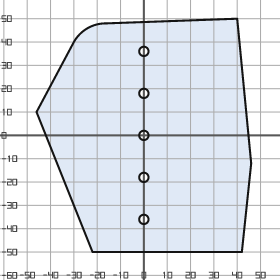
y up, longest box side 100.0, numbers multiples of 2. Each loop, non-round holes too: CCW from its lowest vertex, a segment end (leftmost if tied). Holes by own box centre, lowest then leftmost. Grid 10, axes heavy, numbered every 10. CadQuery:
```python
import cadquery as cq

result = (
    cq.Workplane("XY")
    .moveTo(-22.0, -50.0)
    .lineTo(42.0, -50.0)
    .lineTo(46.0, -12.0)
    .lineTo(40.0, 50.0)
    .lineTo(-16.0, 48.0)
    .threePointArc((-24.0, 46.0), (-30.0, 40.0))
    .lineTo(-46.0, 10.0)
    .close()
    .moveTo(0.0, -36.0)
    .circle(2.0)
    .moveTo(0.0, -18.0)
    .circle(2.0)
    .moveTo(0.0, 0.0)
    .circle(2.0)
    .moveTo(0.0, 18.0)
    .circle(2.0)
    .moveTo(0.0, 36.0)
    .circle(2.0)
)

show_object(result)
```